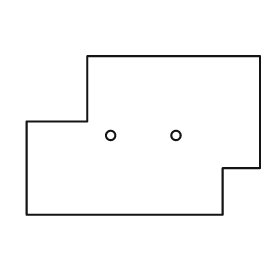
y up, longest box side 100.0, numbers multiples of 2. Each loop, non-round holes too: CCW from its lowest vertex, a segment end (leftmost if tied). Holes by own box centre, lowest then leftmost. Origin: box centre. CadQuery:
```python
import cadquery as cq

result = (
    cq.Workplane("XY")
    .moveTo(-50.0, -34.0)
    .lineTo(34.0, -34.0)
    .lineTo(34.0, -14.0)
    .lineTo(50.0, -14.0)
    .lineTo(50.0, 34.0)
    .lineTo(-24.0, 34.0)
    .lineTo(-24.0, 6.0)
    .lineTo(-50.0, 6.0)
    .close()
    .moveTo(-14.0, 0.0)
    .circle(2.0)
    .moveTo(14.0, 0.0)
    .circle(2.0)
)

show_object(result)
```